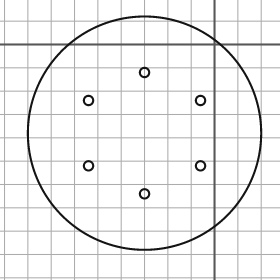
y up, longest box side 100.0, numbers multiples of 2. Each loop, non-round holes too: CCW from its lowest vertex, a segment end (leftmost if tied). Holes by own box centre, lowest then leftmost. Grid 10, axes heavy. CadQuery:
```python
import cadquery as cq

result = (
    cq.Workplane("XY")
    .moveTo(-30.0, -38.0)
    .circle(50.0)
    .moveTo(-30.0, -64.0)
    .circle(2.0)
    .moveTo(-54.0, -52.0)
    .circle(2.0)
    .moveTo(-6.0, -52.0)
    .circle(2.0)
    .moveTo(-54.0, -24.0)
    .circle(2.0)
    .moveTo(-6.0, -24.0)
    .circle(2.0)
    .moveTo(-30.0, -12.0)
    .circle(2.0)
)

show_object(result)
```